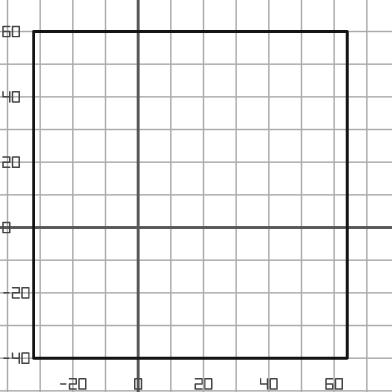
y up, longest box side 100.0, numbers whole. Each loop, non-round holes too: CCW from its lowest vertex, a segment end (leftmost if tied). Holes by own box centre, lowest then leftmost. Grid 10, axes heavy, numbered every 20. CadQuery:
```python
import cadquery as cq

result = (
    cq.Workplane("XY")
    .moveTo(-32.0, -40.0)
    .lineTo(64.0, -40.0)
    .lineTo(64.0, 60.0)
    .lineTo(-32.0, 60.0)
    .close()
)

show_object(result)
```